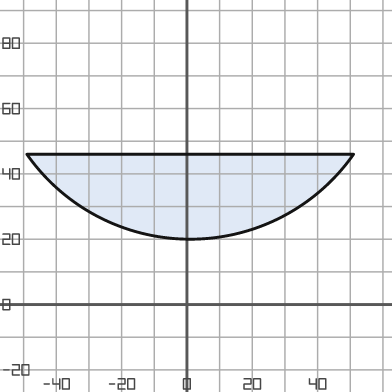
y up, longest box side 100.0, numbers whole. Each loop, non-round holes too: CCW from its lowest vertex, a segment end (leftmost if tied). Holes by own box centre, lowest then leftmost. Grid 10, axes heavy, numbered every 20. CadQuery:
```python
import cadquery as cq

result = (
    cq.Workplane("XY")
    .moveTo(-49.0, 46.0)
    .threePointArc((1.0, 20.0), (51.0, 46.0))
    .close()
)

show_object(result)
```